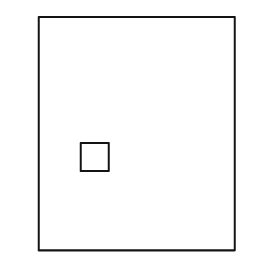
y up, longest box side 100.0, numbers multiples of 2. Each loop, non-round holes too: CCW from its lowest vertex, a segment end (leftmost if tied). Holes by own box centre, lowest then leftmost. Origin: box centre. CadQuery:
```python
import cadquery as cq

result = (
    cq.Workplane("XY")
    .moveTo(-42.0, -50.0)
    .lineTo(42.0, -50.0)
    .lineTo(42.0, 50.0)
    .lineTo(-42.0, 50.0)
    .close()
    .moveTo(-24.0, -16.0)
    .lineTo(-12.0, -16.0)
    .lineTo(-12.0, -4.0)
    .lineTo(-24.0, -4.0)
    .close()
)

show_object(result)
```